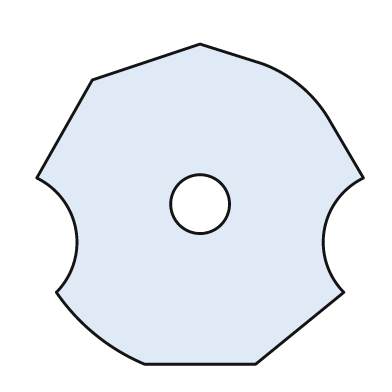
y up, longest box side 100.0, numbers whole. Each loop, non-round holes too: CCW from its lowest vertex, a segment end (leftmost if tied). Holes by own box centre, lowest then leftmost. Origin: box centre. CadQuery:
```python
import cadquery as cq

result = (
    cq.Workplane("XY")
    .moveTo(-17.0, -49.0)
    .lineTo(17.0, -49.0)
    .lineTo(44.0, -27.0)
    .threePointArc((38.0, -8.0), (50.0, 8.0))
    .lineTo(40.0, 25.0)
    .threePointArc((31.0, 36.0), (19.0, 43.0))
    .lineTo(0.0, 49.0)
    .lineTo(-33.0, 38.0)
    .lineTo(-50.0, 8.0)
    .threePointArc((-38.0, -8.0), (-44.0, -27.0))
    .threePointArc((-32.0, -40.0), (-17.0, -49.0))
    .close()
    .moveTo(0.0, 0.0)
    .circle(9.0)
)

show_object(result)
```